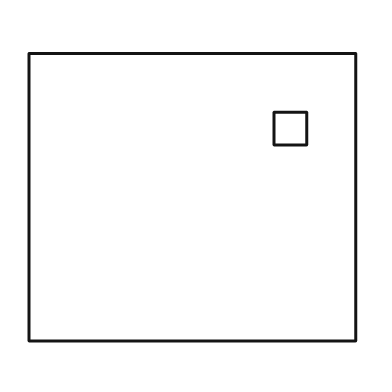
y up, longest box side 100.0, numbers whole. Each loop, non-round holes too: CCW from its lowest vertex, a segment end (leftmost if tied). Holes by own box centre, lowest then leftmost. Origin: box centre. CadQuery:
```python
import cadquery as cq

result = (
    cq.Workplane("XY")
    .moveTo(-50.0, -44.0)
    .lineTo(50.0, -44.0)
    .lineTo(50.0, 44.0)
    .lineTo(-50.0, 44.0)
    .close()
    .moveTo(25.0, 16.0)
    .lineTo(35.0, 16.0)
    .lineTo(35.0, 26.0)
    .lineTo(25.0, 26.0)
    .close()
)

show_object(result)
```